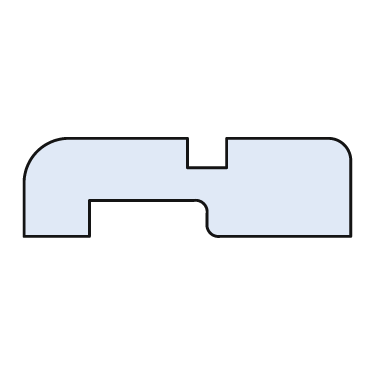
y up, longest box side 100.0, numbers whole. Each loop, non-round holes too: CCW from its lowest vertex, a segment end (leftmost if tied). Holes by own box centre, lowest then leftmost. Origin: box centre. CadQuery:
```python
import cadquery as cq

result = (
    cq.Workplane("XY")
    .moveTo(-50.0, -15.0)
    .lineTo(-30.0, -15.0)
    .lineTo(-30.0, -4.0)
    .lineTo(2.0, -4.0)
    .threePointArc((5.0, -5.0), (6.0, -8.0))
    .lineTo(6.0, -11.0)
    .threePointArc((7.0, -14.0), (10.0, -15.0))
    .lineTo(50.0, -15.0)
    .lineTo(50.0, 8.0)
    .threePointArc((48.0, 13.0), (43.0, 15.0))
    .lineTo(12.0, 15.0)
    .lineTo(12.0, 6.0)
    .lineTo(0.0, 6.0)
    .lineTo(0.0, 15.0)
    .lineTo(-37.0, 15.0)
    .threePointArc((-46.0, 11.0), (-50.0, 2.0))
    .close()
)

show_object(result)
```